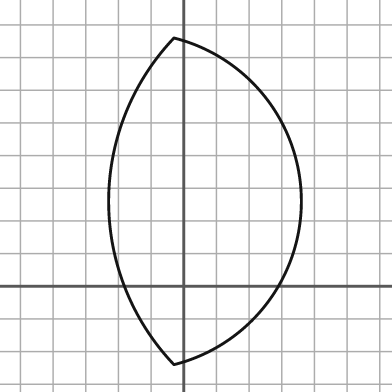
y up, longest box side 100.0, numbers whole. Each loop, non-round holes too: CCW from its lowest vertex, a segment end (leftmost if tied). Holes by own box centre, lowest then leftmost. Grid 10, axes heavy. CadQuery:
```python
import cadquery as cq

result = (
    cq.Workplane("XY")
    .moveTo(-3.0, -24.0)
    .threePointArc((36.0, 26.0), (-3.0, 76.0))
    .threePointArc((-23.0, 26.0), (-3.0, -24.0))
    .close()
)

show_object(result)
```